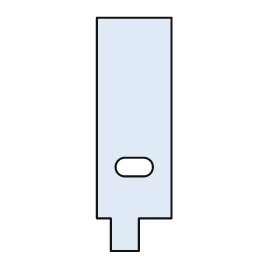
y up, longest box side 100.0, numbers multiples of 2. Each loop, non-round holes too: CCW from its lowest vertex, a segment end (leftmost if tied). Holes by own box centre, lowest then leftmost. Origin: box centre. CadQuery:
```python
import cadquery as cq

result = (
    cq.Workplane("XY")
    .moveTo(-10.0, -50.0)
    .lineTo(2.0, -50.0)
    .lineTo(2.0, -36.0)
    .lineTo(16.0, -36.0)
    .lineTo(16.0, 50.0)
    .lineTo(-16.0, 50.0)
    .lineTo(-16.0, -36.0)
    .lineTo(-10.0, -36.0)
    .close()
    .moveTo(-4.0, -18.0)
    .lineTo(4.0, -18.0)
    .threePointArc((8.0, -14.0), (4.0, -10.0))
    .lineTo(-4.0, -10.0)
    .threePointArc((-8.0, -14.0), (-4.0, -18.0))
    .close()
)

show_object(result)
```